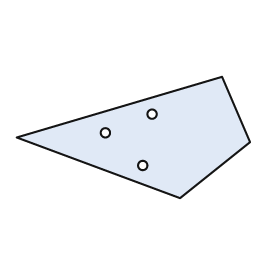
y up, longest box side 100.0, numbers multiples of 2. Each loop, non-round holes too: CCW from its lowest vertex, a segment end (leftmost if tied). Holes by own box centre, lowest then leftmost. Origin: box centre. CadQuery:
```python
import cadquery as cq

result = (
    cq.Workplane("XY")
    .moveTo(20.0, -26.0)
    .lineTo(50.0, -2.0)
    .lineTo(38.0, 26.0)
    .lineTo(-50.0, 0.0)
    .close()
    .moveTo(4.0, -12.0)
    .circle(2.0)
    .moveTo(-12.0, 2.0)
    .circle(2.0)
    .moveTo(8.0, 10.0)
    .circle(2.0)
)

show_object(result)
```